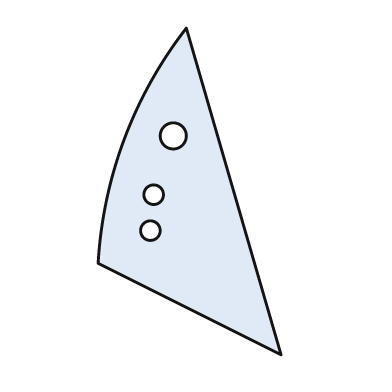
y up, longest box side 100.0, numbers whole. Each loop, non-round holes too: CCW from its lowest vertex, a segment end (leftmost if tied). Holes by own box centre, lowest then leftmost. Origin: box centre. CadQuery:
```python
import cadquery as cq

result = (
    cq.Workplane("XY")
    .moveTo(28.0, -50.0)
    .lineTo(-1.0, 50.0)
    .threePointArc((-20.0, 16.0), (-28.0, -22.0))
    .close()
    .moveTo(-12.0, -12.0)
    .circle(3.0)
    .moveTo(-11.0, -1.0)
    .circle(3.0)
    .moveTo(-5.0, 17.0)
    .circle(4.0)
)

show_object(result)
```